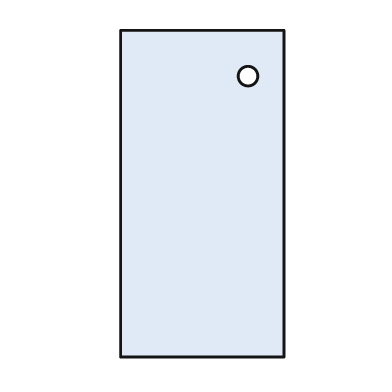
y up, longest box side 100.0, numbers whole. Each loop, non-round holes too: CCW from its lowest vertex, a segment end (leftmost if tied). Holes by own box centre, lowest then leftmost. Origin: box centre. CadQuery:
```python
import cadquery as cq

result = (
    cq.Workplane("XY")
    .moveTo(-25.0, -50.0)
    .lineTo(25.0, -50.0)
    .lineTo(25.0, 50.0)
    .lineTo(-25.0, 50.0)
    .close()
    .moveTo(14.0, 36.0)
    .circle(3.0)
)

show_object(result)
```